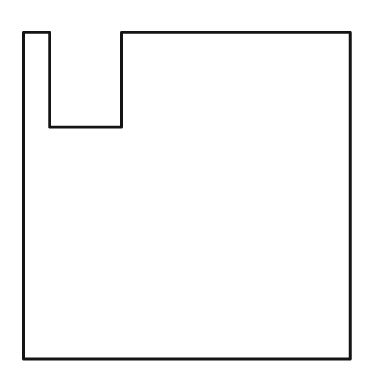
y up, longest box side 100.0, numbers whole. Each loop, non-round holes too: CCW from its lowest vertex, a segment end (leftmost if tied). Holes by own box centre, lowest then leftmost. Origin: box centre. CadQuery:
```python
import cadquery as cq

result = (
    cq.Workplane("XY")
    .moveTo(-50.0, -50.0)
    .lineTo(50.0, -50.0)
    .lineTo(50.0, 50.0)
    .lineTo(-20.0, 50.0)
    .lineTo(-20.0, 21.0)
    .lineTo(-42.0, 21.0)
    .lineTo(-42.0, 50.0)
    .lineTo(-50.0, 50.0)
    .close()
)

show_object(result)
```